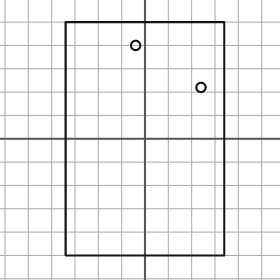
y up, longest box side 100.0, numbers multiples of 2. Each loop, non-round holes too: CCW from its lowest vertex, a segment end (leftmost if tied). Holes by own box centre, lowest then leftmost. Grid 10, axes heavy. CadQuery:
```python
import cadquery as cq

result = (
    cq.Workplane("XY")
    .moveTo(-34.0, -50.0)
    .lineTo(34.0, -50.0)
    .lineTo(34.0, 50.0)
    .lineTo(-34.0, 50.0)
    .close()
    .moveTo(24.0, 22.0)
    .circle(2.0)
    .moveTo(-4.0, 40.0)
    .circle(2.0)
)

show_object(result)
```